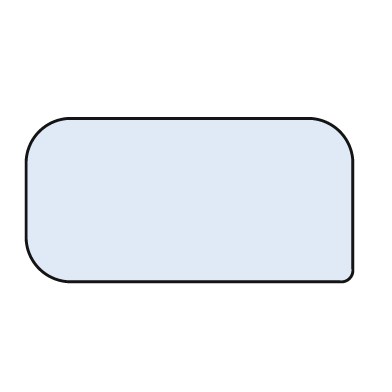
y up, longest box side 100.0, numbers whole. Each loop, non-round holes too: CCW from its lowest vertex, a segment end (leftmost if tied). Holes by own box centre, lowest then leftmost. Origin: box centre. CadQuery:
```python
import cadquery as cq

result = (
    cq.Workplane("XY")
    .moveTo(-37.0, -25.0)
    .lineTo(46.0, -25.0)
    .threePointArc((49.0, -24.0), (50.0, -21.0))
    .lineTo(50.0, 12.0)
    .threePointArc((46.0, 21.0), (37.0, 25.0))
    .lineTo(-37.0, 25.0)
    .threePointArc((-46.0, 21.0), (-50.0, 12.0))
    .lineTo(-50.0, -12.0)
    .threePointArc((-46.0, -21.0), (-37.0, -25.0))
    .close()
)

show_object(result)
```